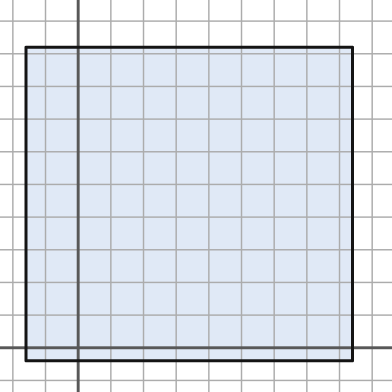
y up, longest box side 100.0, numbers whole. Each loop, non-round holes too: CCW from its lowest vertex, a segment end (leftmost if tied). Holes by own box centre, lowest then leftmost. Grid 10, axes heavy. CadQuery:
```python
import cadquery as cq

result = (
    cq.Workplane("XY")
    .moveTo(-16.0, -4.0)
    .lineTo(84.0, -4.0)
    .lineTo(84.0, 92.0)
    .lineTo(-16.0, 92.0)
    .close()
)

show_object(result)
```